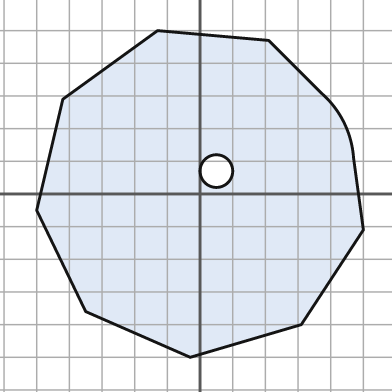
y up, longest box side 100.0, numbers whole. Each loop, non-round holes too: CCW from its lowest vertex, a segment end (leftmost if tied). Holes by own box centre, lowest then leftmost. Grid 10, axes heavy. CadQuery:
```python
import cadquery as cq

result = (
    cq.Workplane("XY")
    .moveTo(-3.0, -50.0)
    .lineTo(31.0, -40.0)
    .lineTo(50.0, -11.0)
    .lineTo(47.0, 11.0)
    .threePointArc((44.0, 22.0), (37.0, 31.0))
    .lineTo(21.0, 47.0)
    .lineTo(-13.0, 50.0)
    .lineTo(-42.0, 29.0)
    .lineTo(-50.0, -5.0)
    .lineTo(-35.0, -36.0)
    .close()
    .moveTo(5.0, 7.0)
    .circle(5.0)
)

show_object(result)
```